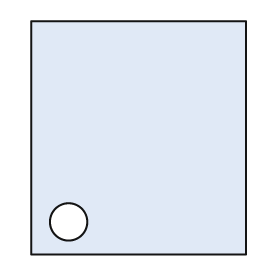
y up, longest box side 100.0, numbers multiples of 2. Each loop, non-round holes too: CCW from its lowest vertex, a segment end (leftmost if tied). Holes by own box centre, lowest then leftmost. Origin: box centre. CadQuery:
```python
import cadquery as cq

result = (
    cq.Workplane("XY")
    .moveTo(-46.0, -50.0)
    .lineTo(46.0, -50.0)
    .lineTo(46.0, 50.0)
    .lineTo(-46.0, 50.0)
    .close()
    .moveTo(-30.0, -36.0)
    .circle(8.0)
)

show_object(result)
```